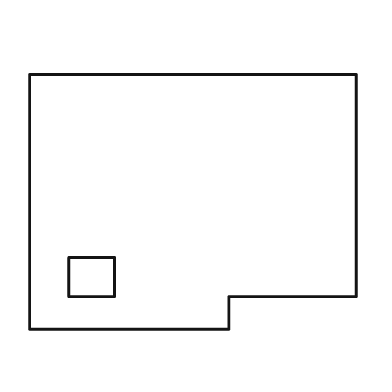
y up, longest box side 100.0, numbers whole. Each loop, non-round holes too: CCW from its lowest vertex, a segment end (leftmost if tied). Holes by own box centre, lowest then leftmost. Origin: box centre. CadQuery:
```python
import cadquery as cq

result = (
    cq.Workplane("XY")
    .moveTo(-50.0, -39.0)
    .lineTo(11.0, -39.0)
    .lineTo(11.0, -29.0)
    .lineTo(50.0, -29.0)
    .lineTo(50.0, 39.0)
    .lineTo(-50.0, 39.0)
    .close()
    .moveTo(-38.0, -29.0)
    .lineTo(-24.0, -29.0)
    .lineTo(-24.0, -17.0)
    .lineTo(-38.0, -17.0)
    .close()
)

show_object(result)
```